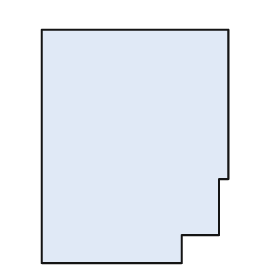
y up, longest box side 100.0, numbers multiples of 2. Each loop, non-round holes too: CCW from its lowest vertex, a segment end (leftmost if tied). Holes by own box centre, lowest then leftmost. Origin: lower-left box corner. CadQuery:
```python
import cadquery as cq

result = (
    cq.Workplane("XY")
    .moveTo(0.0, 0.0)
    .lineTo(60.0, 0.0)
    .lineTo(60.0, 12.0)
    .lineTo(76.0, 12.0)
    .lineTo(76.0, 36.0)
    .lineTo(80.0, 36.0)
    .lineTo(80.0, 100.0)
    .lineTo(0.0, 100.0)
    .close()
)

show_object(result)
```